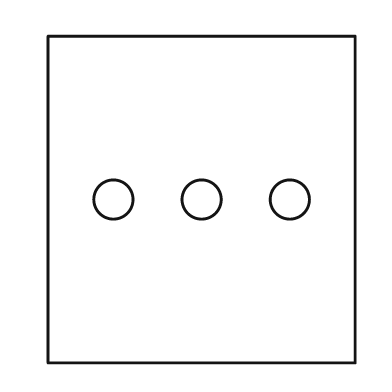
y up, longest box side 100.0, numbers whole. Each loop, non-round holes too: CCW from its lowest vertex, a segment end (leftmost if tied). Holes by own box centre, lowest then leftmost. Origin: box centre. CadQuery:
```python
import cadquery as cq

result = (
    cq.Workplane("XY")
    .moveTo(-47.0, -50.0)
    .lineTo(47.0, -50.0)
    .lineTo(47.0, 50.0)
    .lineTo(-47.0, 50.0)
    .close()
    .moveTo(-27.0, 0.0)
    .circle(6.0)
    .moveTo(0.0, 0.0)
    .circle(6.0)
    .moveTo(27.0, 0.0)
    .circle(6.0)
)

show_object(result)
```